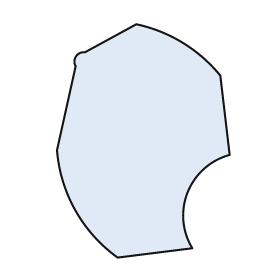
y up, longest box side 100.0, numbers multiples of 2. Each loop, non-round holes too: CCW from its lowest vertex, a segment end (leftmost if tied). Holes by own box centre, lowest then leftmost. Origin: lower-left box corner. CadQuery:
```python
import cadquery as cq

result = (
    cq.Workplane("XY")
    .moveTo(26.0, 0.0)
    .lineTo(58.0, 4.0)
    .threePointArc((56.0, 28.0), (74.0, 44.0))
    .lineTo(70.0, 78.0)
    .threePointArc((54.0, 92.0), (34.0, 100.0))
    .lineTo(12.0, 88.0)
    .threePointArc((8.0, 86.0), (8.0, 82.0))
    .lineTo(0.0, 46.0)
    .threePointArc((8.0, 20.0), (26.0, 0.0))
    .close()
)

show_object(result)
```